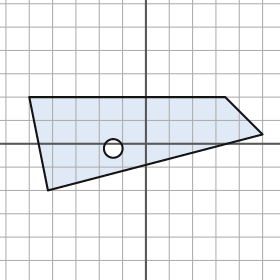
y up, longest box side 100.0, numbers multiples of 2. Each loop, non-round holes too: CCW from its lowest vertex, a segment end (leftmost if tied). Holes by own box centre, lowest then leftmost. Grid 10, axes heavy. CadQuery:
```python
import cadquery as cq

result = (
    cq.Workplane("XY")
    .moveTo(-42.0, -20.0)
    .lineTo(50.0, 4.0)
    .lineTo(34.0, 20.0)
    .lineTo(-50.0, 20.0)
    .close()
    .moveTo(-14.0, -2.0)
    .circle(4.0)
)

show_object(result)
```